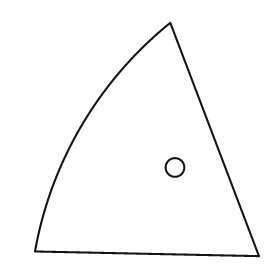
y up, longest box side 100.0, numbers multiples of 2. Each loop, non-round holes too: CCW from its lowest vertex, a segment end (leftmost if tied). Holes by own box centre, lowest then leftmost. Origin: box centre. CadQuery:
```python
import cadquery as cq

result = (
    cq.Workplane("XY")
    .moveTo(48.0, -50.0)
    .lineTo(10.0, 50.0)
    .threePointArc((-28.0, 6.0), (-48.0, -48.0))
    .close()
    .moveTo(12.0, -12.0)
    .circle(4.0)
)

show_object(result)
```